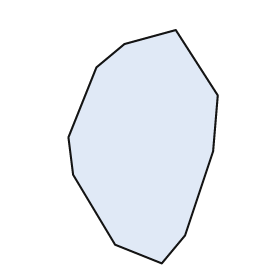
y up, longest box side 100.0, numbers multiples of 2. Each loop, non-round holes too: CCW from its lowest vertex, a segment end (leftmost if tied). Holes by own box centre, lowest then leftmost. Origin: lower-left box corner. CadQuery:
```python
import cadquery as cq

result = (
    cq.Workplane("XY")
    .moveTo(40.0, 0.0)
    .lineTo(50.0, 12.0)
    .lineTo(62.0, 48.0)
    .lineTo(64.0, 72.0)
    .lineTo(46.0, 100.0)
    .lineTo(24.0, 94.0)
    .lineTo(12.0, 84.0)
    .lineTo(0.0, 54.0)
    .lineTo(2.0, 38.0)
    .lineTo(20.0, 8.0)
    .close()
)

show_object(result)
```